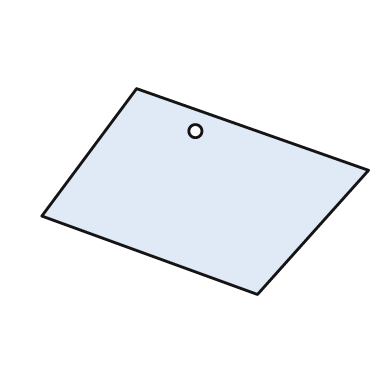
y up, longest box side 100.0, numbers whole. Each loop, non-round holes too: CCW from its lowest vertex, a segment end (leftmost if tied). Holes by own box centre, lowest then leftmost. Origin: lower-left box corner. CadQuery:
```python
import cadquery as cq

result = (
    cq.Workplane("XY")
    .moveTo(66.0, 0.0)
    .lineTo(100.0, 38.0)
    .lineTo(29.0, 63.0)
    .lineTo(0.0, 24.0)
    .close()
    .moveTo(47.0, 50.0)
    .circle(2.0)
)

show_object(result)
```